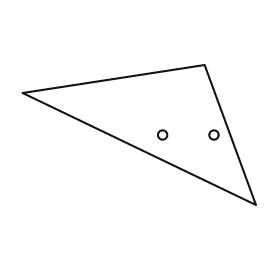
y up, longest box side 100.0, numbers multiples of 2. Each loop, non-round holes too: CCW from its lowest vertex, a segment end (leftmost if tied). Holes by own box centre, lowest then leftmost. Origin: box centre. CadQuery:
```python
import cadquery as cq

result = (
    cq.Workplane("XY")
    .moveTo(50.0, -30.0)
    .lineTo(28.0, 30.0)
    .lineTo(-50.0, 18.0)
    .close()
    .moveTo(10.0, 0.0)
    .circle(2.0)
    .moveTo(32.0, 0.0)
    .circle(2.0)
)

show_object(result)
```